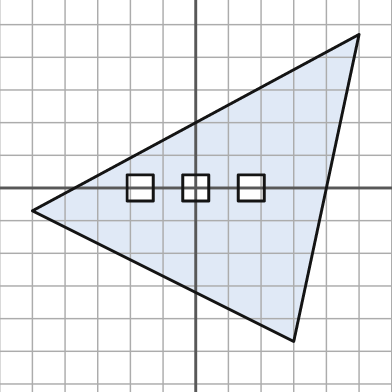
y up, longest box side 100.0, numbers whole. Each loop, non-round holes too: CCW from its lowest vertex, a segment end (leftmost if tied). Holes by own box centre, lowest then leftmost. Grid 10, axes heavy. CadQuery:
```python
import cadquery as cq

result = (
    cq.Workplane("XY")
    .moveTo(30.0, -47.0)
    .lineTo(50.0, 47.0)
    .lineTo(-50.0, -7.0)
    .close()
    .moveTo(-21.0, -4.0)
    .lineTo(-13.0, -4.0)
    .lineTo(-13.0, 4.0)
    .lineTo(-21.0, 4.0)
    .close()
    .moveTo(-4.0, -4.0)
    .lineTo(4.0, -4.0)
    .lineTo(4.0, 4.0)
    .lineTo(-4.0, 4.0)
    .close()
    .moveTo(13.0, -4.0)
    .lineTo(21.0, -4.0)
    .lineTo(21.0, 4.0)
    .lineTo(13.0, 4.0)
    .close()
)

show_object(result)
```